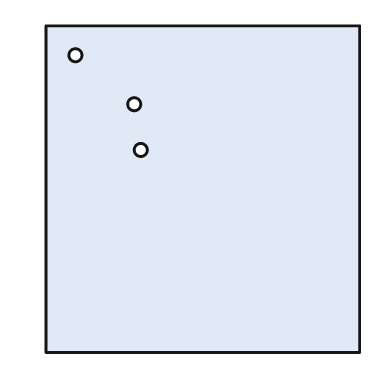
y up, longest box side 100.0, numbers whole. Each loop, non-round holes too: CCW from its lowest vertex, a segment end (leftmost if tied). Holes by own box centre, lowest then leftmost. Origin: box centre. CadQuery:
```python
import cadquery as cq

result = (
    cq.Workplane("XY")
    .moveTo(-48.0, -50.0)
    .lineTo(48.0, -50.0)
    .lineTo(48.0, 50.0)
    .lineTo(-48.0, 50.0)
    .close()
    .moveTo(-19.0, 12.0)
    .circle(2.0)
    .moveTo(-21.0, 26.0)
    .circle(2.0)
    .moveTo(-39.0, 41.0)
    .circle(2.0)
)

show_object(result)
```